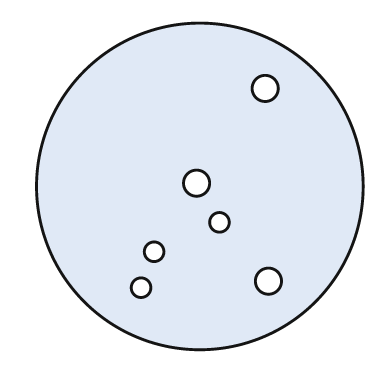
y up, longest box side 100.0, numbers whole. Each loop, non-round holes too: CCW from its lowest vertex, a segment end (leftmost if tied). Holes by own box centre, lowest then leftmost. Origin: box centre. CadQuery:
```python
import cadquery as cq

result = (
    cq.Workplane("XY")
    .moveTo(0.0, 0.0)
    .circle(50.0)
    .moveTo(-18.0, -31.0)
    .circle(3.0)
    .moveTo(21.0, -29.0)
    .circle(4.0)
    .moveTo(-14.0, -20.0)
    .circle(3.0)
    .moveTo(6.0, -11.0)
    .circle(3.0)
    .moveTo(-1.0, 1.0)
    .circle(4.0)
    .moveTo(20.0, 30.0)
    .circle(4.0)
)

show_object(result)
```